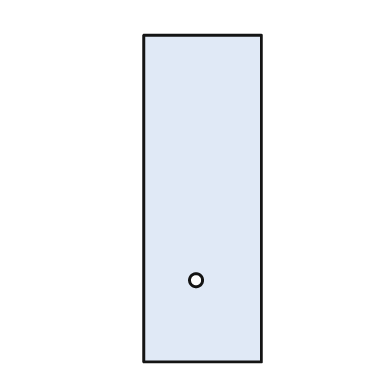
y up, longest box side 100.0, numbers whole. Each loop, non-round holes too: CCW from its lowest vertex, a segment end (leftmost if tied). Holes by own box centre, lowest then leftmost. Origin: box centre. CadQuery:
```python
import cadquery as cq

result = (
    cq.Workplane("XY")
    .moveTo(-18.0, -50.0)
    .lineTo(18.0, -50.0)
    .lineTo(18.0, 50.0)
    .lineTo(-18.0, 50.0)
    .close()
    .moveTo(-2.0, -25.0)
    .circle(2.0)
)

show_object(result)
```